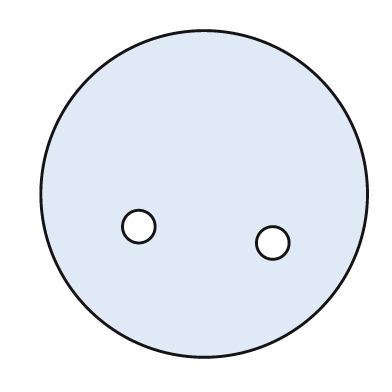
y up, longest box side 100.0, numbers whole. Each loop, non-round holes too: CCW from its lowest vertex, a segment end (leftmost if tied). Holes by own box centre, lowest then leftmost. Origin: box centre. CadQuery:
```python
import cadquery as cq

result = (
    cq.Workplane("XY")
    .moveTo(0.0, 0.0)
    .circle(50.0)
    .moveTo(21.0, -15.0)
    .circle(5.0)
    .moveTo(-20.0, -10.0)
    .circle(5.0)
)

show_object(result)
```